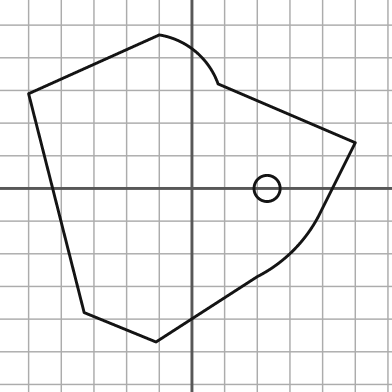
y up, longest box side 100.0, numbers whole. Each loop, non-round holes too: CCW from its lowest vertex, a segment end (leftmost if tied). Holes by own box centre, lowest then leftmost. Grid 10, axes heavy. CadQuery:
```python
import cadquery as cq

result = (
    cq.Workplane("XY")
    .moveTo(-11.0, -47.0)
    .lineTo(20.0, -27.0)
    .threePointArc((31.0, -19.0), (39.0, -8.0))
    .lineTo(50.0, 14.0)
    .lineTo(8.0, 32.0)
    .threePointArc((1.0, 42.0), (-10.0, 47.0))
    .lineTo(-50.0, 29.0)
    .lineTo(-33.0, -38.0)
    .close()
    .moveTo(23.0, 0.0)
    .circle(4.0)
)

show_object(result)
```